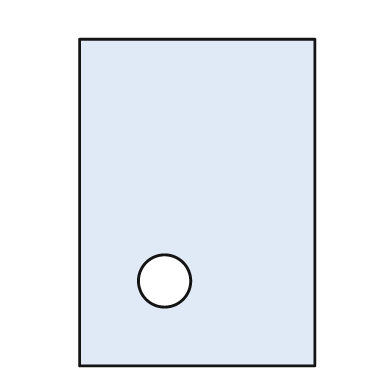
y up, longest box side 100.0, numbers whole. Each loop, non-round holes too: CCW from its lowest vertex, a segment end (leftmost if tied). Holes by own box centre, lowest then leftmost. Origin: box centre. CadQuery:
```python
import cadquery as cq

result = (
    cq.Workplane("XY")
    .moveTo(-36.0, -50.0)
    .lineTo(36.0, -50.0)
    .lineTo(36.0, 50.0)
    .lineTo(-36.0, 50.0)
    .close()
    .moveTo(-10.0, -24.0)
    .circle(8.0)
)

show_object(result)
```